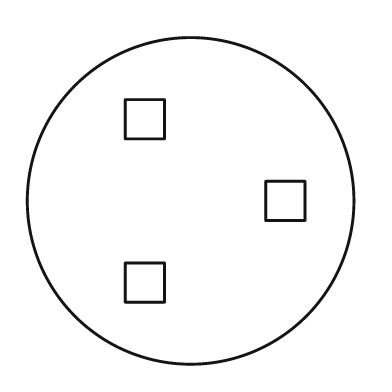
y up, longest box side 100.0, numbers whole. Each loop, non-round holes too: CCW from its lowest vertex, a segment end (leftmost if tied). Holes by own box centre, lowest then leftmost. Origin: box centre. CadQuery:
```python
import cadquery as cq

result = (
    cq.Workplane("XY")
    .moveTo(0.0, 0.0)
    .circle(50.0)
    .moveTo(-20.0, -31.0)
    .lineTo(-8.0, -31.0)
    .lineTo(-8.0, -19.0)
    .lineTo(-20.0, -19.0)
    .close()
    .moveTo(23.0, -6.0)
    .lineTo(35.0, -6.0)
    .lineTo(35.0, 6.0)
    .lineTo(23.0, 6.0)
    .close()
    .moveTo(-20.0, 19.0)
    .lineTo(-8.0, 19.0)
    .lineTo(-8.0, 31.0)
    .lineTo(-20.0, 31.0)
    .close()
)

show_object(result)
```